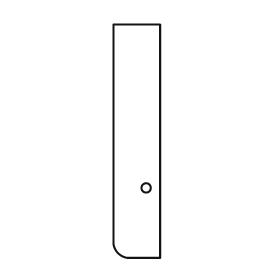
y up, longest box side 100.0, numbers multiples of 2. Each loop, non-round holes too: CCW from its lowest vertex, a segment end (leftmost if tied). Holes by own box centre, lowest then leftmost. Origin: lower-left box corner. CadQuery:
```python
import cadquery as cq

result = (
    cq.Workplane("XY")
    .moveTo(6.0, 0.0)
    .lineTo(20.0, 0.0)
    .lineTo(20.0, 100.0)
    .lineTo(0.0, 100.0)
    .lineTo(0.0, 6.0)
    .threePointArc((2.0, 2.0), (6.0, 0.0))
    .close()
    .moveTo(14.0, 30.0)
    .circle(2.0)
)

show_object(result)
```